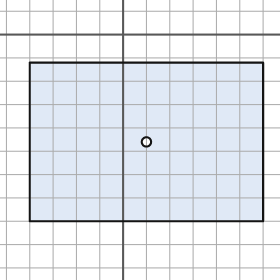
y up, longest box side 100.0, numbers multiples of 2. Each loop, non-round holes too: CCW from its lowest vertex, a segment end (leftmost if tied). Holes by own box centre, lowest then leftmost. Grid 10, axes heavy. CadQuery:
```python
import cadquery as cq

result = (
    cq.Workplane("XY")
    .moveTo(-40.0, -80.0)
    .lineTo(60.0, -80.0)
    .lineTo(60.0, -12.0)
    .lineTo(-40.0, -12.0)
    .close()
    .moveTo(10.0, -46.0)
    .circle(2.0)
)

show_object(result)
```